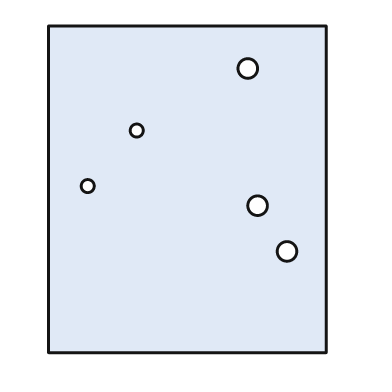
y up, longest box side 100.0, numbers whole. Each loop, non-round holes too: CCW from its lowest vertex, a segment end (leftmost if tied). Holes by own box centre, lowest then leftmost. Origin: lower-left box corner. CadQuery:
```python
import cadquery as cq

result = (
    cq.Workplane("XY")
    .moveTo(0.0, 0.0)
    .lineTo(85.0, 0.0)
    .lineTo(85.0, 100.0)
    .lineTo(0.0, 100.0)
    .close()
    .moveTo(73.0, 31.0)
    .circle(3.0)
    .moveTo(64.0, 45.0)
    .circle(3.0)
    .moveTo(12.0, 51.0)
    .circle(2.0)
    .moveTo(27.0, 68.0)
    .circle(2.0)
    .moveTo(61.0, 87.0)
    .circle(3.0)
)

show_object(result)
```